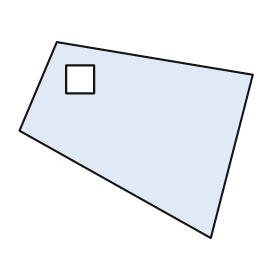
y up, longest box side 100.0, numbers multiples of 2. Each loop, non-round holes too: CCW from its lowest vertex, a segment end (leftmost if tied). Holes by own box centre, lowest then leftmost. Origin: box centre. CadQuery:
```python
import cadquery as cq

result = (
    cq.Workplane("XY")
    .moveTo(32.0, -42.0)
    .lineTo(50.0, 28.0)
    .lineTo(-34.0, 42.0)
    .lineTo(-50.0, 4.0)
    .close()
    .moveTo(-30.0, 20.0)
    .lineTo(-18.0, 20.0)
    .lineTo(-18.0, 32.0)
    .lineTo(-30.0, 32.0)
    .close()
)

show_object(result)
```